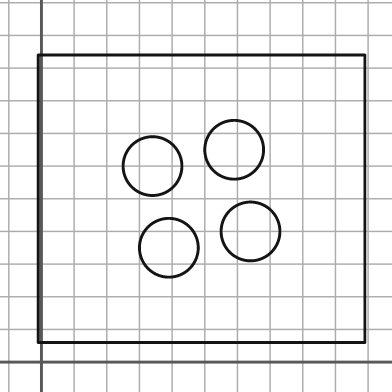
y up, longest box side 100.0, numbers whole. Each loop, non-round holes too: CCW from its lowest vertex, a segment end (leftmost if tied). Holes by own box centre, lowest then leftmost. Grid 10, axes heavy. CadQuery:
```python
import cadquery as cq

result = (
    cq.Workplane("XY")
    .moveTo(-1.0, 6.0)
    .lineTo(99.0, 6.0)
    .lineTo(99.0, 94.0)
    .lineTo(-1.0, 94.0)
    .close()
    .moveTo(39.0, 35.0)
    .circle(9.0)
    .moveTo(64.0, 40.0)
    .circle(9.0)
    .moveTo(34.0, 60.0)
    .circle(9.0)
    .moveTo(59.0, 65.0)
    .circle(9.0)
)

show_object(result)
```